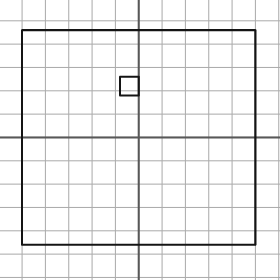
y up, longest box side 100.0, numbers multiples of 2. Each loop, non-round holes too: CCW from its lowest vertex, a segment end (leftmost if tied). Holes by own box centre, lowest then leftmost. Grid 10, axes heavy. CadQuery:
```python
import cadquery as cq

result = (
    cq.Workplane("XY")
    .moveTo(-50.0, -46.0)
    .lineTo(50.0, -46.0)
    .lineTo(50.0, 46.0)
    .lineTo(-50.0, 46.0)
    .close()
    .moveTo(-8.0, 18.0)
    .lineTo(0.0, 18.0)
    .lineTo(0.0, 26.0)
    .lineTo(-8.0, 26.0)
    .close()
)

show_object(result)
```